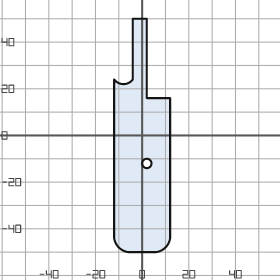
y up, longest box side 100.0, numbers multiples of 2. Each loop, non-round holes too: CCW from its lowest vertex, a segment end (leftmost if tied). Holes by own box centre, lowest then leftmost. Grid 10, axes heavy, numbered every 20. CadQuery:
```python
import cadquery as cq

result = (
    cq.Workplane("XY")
    .moveTo(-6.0, -50.0)
    .lineTo(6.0, -50.0)
    .threePointArc((10.0, -48.0), (12.0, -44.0))
    .lineTo(12.0, 16.0)
    .lineTo(2.0, 16.0)
    .lineTo(2.0, 50.0)
    .lineTo(-4.0, 50.0)
    .lineTo(-4.0, 24.0)
    .threePointArc((-8.0, 22.0), (-12.0, 24.0))
    .lineTo(-12.0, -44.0)
    .threePointArc((-10.0, -48.0), (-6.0, -50.0))
    .close()
    .moveTo(2.0, -12.0)
    .circle(2.0)
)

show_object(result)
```